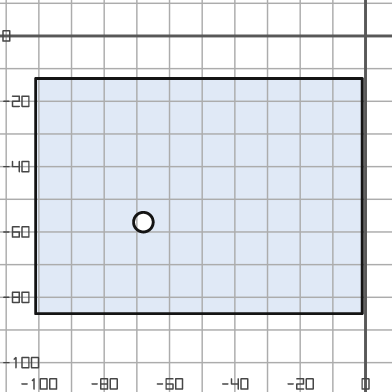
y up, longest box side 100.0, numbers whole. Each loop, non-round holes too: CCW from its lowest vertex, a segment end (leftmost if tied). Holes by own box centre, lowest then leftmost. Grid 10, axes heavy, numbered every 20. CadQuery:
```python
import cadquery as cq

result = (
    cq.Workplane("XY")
    .moveTo(-101.0, -85.0)
    .lineTo(-1.0, -85.0)
    .lineTo(-1.0, -13.0)
    .lineTo(-101.0, -13.0)
    .close()
    .moveTo(-68.0, -57.0)
    .circle(3.0)
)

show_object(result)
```